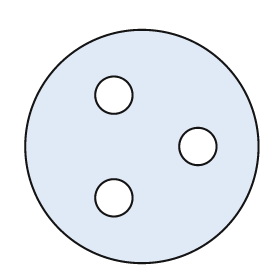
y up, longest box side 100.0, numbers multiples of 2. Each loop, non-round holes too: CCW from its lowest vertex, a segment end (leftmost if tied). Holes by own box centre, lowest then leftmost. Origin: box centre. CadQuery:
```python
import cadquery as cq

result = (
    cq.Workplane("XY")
    .moveTo(0.0, 0.0)
    .circle(50.0)
    .moveTo(-12.0, -22.0)
    .circle(8.0)
    .moveTo(24.0, 0.0)
    .circle(8.0)
    .moveTo(-12.0, 22.0)
    .circle(8.0)
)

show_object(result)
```